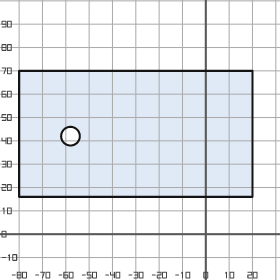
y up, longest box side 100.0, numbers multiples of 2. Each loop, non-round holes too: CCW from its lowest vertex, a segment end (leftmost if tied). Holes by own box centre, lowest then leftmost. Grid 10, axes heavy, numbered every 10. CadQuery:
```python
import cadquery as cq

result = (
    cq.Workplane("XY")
    .moveTo(-80.0, 16.0)
    .lineTo(20.0, 16.0)
    .lineTo(20.0, 70.0)
    .lineTo(-80.0, 70.0)
    .close()
    .moveTo(-58.0, 42.0)
    .circle(4.0)
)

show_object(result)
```